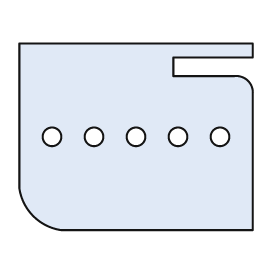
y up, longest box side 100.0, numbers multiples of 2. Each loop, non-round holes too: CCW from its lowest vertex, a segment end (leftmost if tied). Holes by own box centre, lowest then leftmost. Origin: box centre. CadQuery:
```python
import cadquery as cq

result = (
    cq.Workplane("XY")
    .moveTo(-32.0, -40.0)
    .lineTo(50.0, -40.0)
    .lineTo(50.0, 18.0)
    .threePointArc((48.0, 24.0), (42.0, 26.0))
    .lineTo(16.0, 26.0)
    .lineTo(16.0, 34.0)
    .lineTo(50.0, 34.0)
    .lineTo(50.0, 40.0)
    .lineTo(-50.0, 40.0)
    .lineTo(-50.0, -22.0)
    .threePointArc((-44.0, -34.0), (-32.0, -40.0))
    .close()
    .moveTo(-36.0, 0.0)
    .circle(4.0)
    .moveTo(-18.0, 0.0)
    .circle(4.0)
    .moveTo(0.0, 0.0)
    .circle(4.0)
    .moveTo(18.0, 0.0)
    .circle(4.0)
    .moveTo(36.0, 0.0)
    .circle(4.0)
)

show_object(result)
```